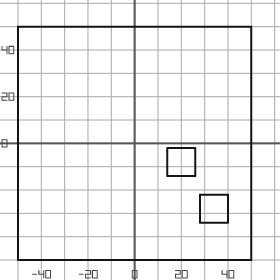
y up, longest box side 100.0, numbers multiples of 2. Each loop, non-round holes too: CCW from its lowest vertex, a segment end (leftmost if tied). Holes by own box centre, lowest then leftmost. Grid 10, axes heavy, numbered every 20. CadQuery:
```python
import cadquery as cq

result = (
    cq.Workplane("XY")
    .moveTo(-50.0, -50.0)
    .lineTo(50.0, -50.0)
    .lineTo(50.0, 50.0)
    .lineTo(-50.0, 50.0)
    .close()
    .moveTo(28.0, -34.0)
    .lineTo(40.0, -34.0)
    .lineTo(40.0, -22.0)
    .lineTo(28.0, -22.0)
    .close()
    .moveTo(14.0, -14.0)
    .lineTo(26.0, -14.0)
    .lineTo(26.0, -2.0)
    .lineTo(14.0, -2.0)
    .close()
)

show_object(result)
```